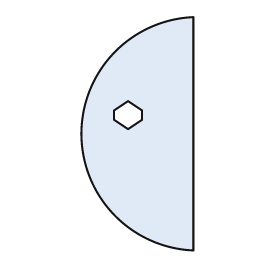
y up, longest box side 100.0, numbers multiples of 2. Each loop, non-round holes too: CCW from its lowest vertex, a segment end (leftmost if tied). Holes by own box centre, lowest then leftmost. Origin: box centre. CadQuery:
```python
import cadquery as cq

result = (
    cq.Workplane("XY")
    .moveTo(24.0, -50.0)
    .lineTo(24.0, 50.0)
    .threePointArc((-24.0, 0.0), (24.0, -50.0))
    .close()
    .moveTo(-4.0, 2.0)
    .lineTo(2.0, 6.0)
    .lineTo(2.0, 10.0)
    .lineTo(-4.0, 14.0)
    .lineTo(-10.0, 10.0)
    .lineTo(-10.0, 6.0)
    .close()
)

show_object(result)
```